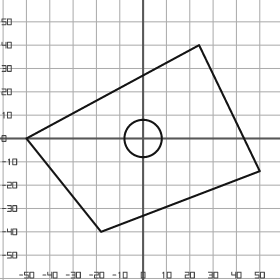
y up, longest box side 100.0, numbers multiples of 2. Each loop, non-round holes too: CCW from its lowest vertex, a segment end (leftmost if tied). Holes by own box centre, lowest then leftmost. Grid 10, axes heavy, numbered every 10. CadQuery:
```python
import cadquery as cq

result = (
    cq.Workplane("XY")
    .moveTo(-18.0, -40.0)
    .lineTo(50.0, -14.0)
    .lineTo(24.0, 40.0)
    .lineTo(-50.0, 0.0)
    .close()
    .moveTo(0.0, 0.0)
    .circle(8.0)
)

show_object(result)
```